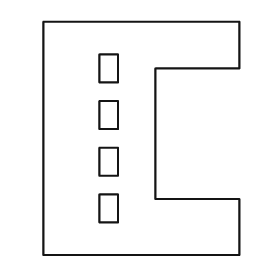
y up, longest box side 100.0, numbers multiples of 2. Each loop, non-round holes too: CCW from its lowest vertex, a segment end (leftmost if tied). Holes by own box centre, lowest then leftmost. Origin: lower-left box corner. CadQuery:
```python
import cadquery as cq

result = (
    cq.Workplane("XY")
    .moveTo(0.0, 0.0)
    .lineTo(84.0, 0.0)
    .lineTo(84.0, 24.0)
    .lineTo(48.0, 24.0)
    .lineTo(48.0, 80.0)
    .lineTo(84.0, 80.0)
    .lineTo(84.0, 100.0)
    .lineTo(0.0, 100.0)
    .close()
    .moveTo(24.0, 14.0)
    .lineTo(32.0, 14.0)
    .lineTo(32.0, 26.0)
    .lineTo(24.0, 26.0)
    .close()
    .moveTo(24.0, 34.0)
    .lineTo(32.0, 34.0)
    .lineTo(32.0, 46.0)
    .lineTo(24.0, 46.0)
    .close()
    .moveTo(24.0, 54.0)
    .lineTo(32.0, 54.0)
    .lineTo(32.0, 66.0)
    .lineTo(24.0, 66.0)
    .close()
    .moveTo(24.0, 74.0)
    .lineTo(32.0, 74.0)
    .lineTo(32.0, 86.0)
    .lineTo(24.0, 86.0)
    .close()
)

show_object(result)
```